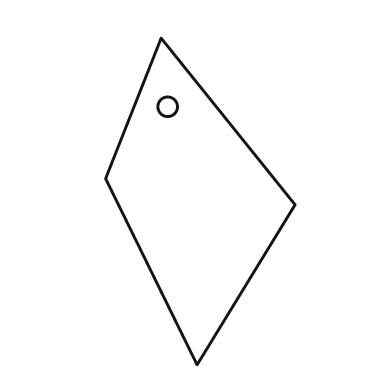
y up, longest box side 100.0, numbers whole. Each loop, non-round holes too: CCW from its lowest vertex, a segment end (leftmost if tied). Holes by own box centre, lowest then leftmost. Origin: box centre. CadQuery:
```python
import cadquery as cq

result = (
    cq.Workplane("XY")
    .moveTo(-1.0, -50.0)
    .lineTo(29.0, -1.0)
    .lineTo(-12.0, 50.0)
    .lineTo(-29.0, 7.0)
    .close()
    .moveTo(-10.0, 29.0)
    .circle(3.0)
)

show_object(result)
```